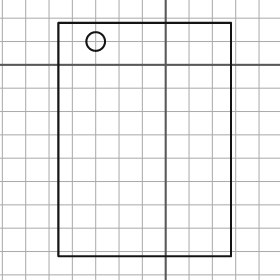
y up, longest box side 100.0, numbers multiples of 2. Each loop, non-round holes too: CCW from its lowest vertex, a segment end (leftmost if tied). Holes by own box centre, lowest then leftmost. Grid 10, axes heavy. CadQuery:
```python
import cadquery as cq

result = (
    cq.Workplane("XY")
    .moveTo(-46.0, -82.0)
    .lineTo(28.0, -82.0)
    .lineTo(28.0, 18.0)
    .lineTo(-46.0, 18.0)
    .close()
    .moveTo(-30.0, 10.0)
    .circle(4.0)
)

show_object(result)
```